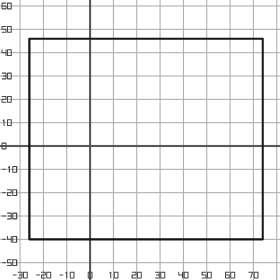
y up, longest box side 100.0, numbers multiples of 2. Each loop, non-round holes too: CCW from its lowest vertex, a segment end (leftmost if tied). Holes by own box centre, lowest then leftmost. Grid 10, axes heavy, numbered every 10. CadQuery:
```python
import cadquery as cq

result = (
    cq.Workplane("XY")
    .moveTo(-26.0, -40.0)
    .lineTo(74.0, -40.0)
    .lineTo(74.0, 46.0)
    .lineTo(-26.0, 46.0)
    .close()
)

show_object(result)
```